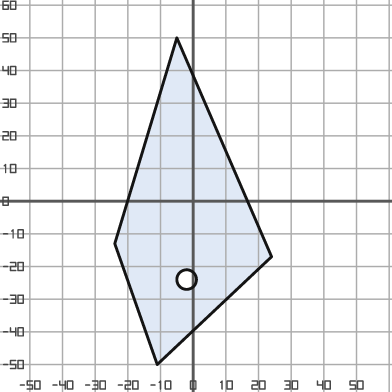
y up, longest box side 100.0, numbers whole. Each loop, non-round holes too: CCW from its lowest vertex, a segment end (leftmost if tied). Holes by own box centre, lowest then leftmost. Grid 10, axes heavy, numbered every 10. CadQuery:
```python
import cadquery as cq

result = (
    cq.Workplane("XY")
    .moveTo(-11.0, -50.0)
    .lineTo(24.0, -17.0)
    .lineTo(-5.0, 50.0)
    .lineTo(-24.0, -13.0)
    .close()
    .moveTo(-2.0, -24.0)
    .circle(3.0)
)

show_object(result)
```